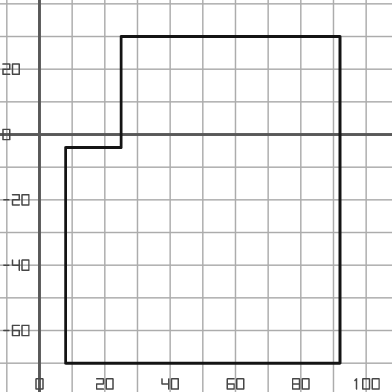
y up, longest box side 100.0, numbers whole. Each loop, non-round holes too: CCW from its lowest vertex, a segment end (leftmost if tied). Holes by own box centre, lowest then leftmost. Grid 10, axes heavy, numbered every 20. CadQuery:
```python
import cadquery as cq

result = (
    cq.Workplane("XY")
    .moveTo(8.0, -70.0)
    .lineTo(92.0, -70.0)
    .lineTo(92.0, 30.0)
    .lineTo(25.0, 30.0)
    .lineTo(25.0, -4.0)
    .lineTo(8.0, -4.0)
    .close()
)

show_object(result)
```